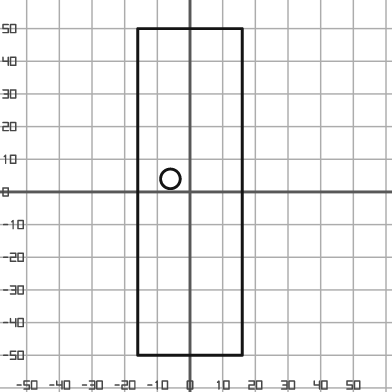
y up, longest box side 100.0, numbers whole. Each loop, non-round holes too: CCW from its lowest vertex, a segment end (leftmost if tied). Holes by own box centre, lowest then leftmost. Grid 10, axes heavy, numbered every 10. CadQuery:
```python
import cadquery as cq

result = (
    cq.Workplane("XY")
    .moveTo(-16.0, -50.0)
    .lineTo(16.0, -50.0)
    .lineTo(16.0, 50.0)
    .lineTo(-16.0, 50.0)
    .close()
    .moveTo(-6.0, 4.0)
    .circle(3.0)
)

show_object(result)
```